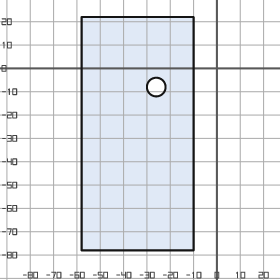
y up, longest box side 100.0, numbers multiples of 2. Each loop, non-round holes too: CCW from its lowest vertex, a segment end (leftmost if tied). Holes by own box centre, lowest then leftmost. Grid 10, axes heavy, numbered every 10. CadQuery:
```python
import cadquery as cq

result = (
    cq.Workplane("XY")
    .moveTo(-58.0, -78.0)
    .lineTo(-10.0, -78.0)
    .lineTo(-10.0, 22.0)
    .lineTo(-58.0, 22.0)
    .close()
    .moveTo(-26.0, -8.0)
    .circle(4.0)
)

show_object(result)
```